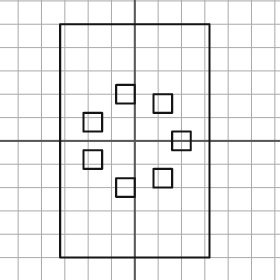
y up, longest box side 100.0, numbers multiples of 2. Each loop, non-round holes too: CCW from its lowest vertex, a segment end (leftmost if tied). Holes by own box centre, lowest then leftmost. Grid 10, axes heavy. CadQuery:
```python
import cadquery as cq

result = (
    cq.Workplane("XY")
    .moveTo(-32.0, -50.0)
    .lineTo(32.0, -50.0)
    .lineTo(32.0, 50.0)
    .lineTo(-32.0, 50.0)
    .close()
    .moveTo(-8.0, -24.0)
    .lineTo(0.0, -24.0)
    .lineTo(0.0, -16.0)
    .lineTo(-8.0, -16.0)
    .close()
    .moveTo(8.0, -20.0)
    .lineTo(16.0, -20.0)
    .lineTo(16.0, -12.0)
    .lineTo(8.0, -12.0)
    .close()
    .moveTo(-22.0, -12.0)
    .lineTo(-14.0, -12.0)
    .lineTo(-14.0, -4.0)
    .lineTo(-22.0, -4.0)
    .close()
    .moveTo(16.0, -4.0)
    .lineTo(24.0, -4.0)
    .lineTo(24.0, 4.0)
    .lineTo(16.0, 4.0)
    .close()
    .moveTo(-22.0, 4.0)
    .lineTo(-14.0, 4.0)
    .lineTo(-14.0, 12.0)
    .lineTo(-22.0, 12.0)
    .close()
    .moveTo(8.0, 12.0)
    .lineTo(16.0, 12.0)
    .lineTo(16.0, 20.0)
    .lineTo(8.0, 20.0)
    .close()
    .moveTo(-8.0, 16.0)
    .lineTo(0.0, 16.0)
    .lineTo(0.0, 24.0)
    .lineTo(-8.0, 24.0)
    .close()
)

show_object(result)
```